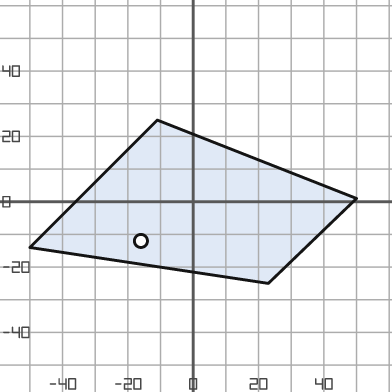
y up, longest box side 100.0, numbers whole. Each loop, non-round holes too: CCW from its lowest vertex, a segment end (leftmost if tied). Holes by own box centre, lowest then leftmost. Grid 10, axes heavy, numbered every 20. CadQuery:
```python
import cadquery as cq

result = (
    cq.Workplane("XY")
    .moveTo(23.0, -25.0)
    .lineTo(50.0, 1.0)
    .lineTo(-11.0, 25.0)
    .lineTo(-50.0, -14.0)
    .close()
    .moveTo(-16.0, -12.0)
    .circle(2.0)
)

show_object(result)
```